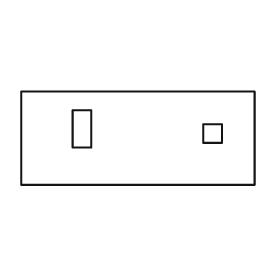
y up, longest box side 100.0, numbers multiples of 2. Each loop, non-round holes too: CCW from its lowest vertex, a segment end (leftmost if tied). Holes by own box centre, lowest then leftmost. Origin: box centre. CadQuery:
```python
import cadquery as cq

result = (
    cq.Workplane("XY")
    .moveTo(-50.0, -20.0)
    .lineTo(50.0, -20.0)
    .lineTo(50.0, 20.0)
    .lineTo(-50.0, 20.0)
    .close()
    .moveTo(28.0, -2.0)
    .lineTo(36.0, -2.0)
    .lineTo(36.0, 6.0)
    .lineTo(28.0, 6.0)
    .close()
    .moveTo(-28.0, -4.0)
    .lineTo(-20.0, -4.0)
    .lineTo(-20.0, 12.0)
    .lineTo(-28.0, 12.0)
    .close()
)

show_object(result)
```